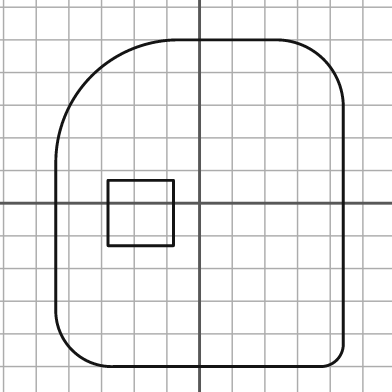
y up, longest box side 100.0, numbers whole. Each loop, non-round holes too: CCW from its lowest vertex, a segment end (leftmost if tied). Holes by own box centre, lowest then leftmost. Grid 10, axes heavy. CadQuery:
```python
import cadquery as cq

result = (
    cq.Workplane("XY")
    .moveTo(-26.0, -50.0)
    .lineTo(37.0, -50.0)
    .threePointArc((42.0, -48.0), (44.0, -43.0))
    .lineTo(44.0, 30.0)
    .threePointArc((38.0, 44.0), (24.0, 50.0))
    .lineTo(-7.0, 50.0)
    .threePointArc((-33.0, 39.0), (-44.0, 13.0))
    .lineTo(-44.0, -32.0)
    .threePointArc((-39.0, -45.0), (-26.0, -50.0))
    .close()
    .moveTo(-28.0, -13.0)
    .lineTo(-8.0, -13.0)
    .lineTo(-8.0, 7.0)
    .lineTo(-28.0, 7.0)
    .close()
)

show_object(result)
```